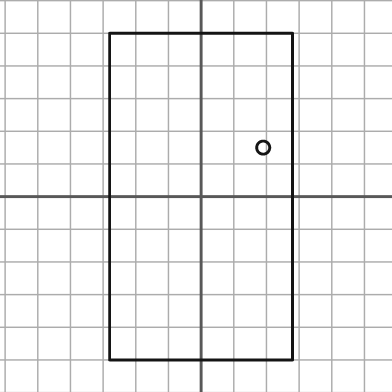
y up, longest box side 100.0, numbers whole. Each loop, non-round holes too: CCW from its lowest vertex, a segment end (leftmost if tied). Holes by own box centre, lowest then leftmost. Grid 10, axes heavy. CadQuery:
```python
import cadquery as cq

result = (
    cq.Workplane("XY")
    .moveTo(-28.0, -50.0)
    .lineTo(28.0, -50.0)
    .lineTo(28.0, 50.0)
    .lineTo(-28.0, 50.0)
    .close()
    .moveTo(19.0, 15.0)
    .circle(2.0)
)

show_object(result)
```